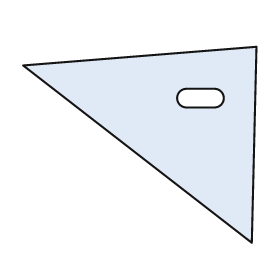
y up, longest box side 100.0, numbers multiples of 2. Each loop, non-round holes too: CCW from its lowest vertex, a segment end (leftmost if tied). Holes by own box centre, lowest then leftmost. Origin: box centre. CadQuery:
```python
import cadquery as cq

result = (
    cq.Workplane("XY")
    .moveTo(48.0, -42.0)
    .lineTo(50.0, 42.0)
    .lineTo(-50.0, 34.0)
    .close()
    .moveTo(20.0, 16.0)
    .lineTo(32.0, 16.0)
    .threePointArc((36.0, 20.0), (32.0, 24.0))
    .lineTo(20.0, 24.0)
    .threePointArc((16.0, 20.0), (20.0, 16.0))
    .close()
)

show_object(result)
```